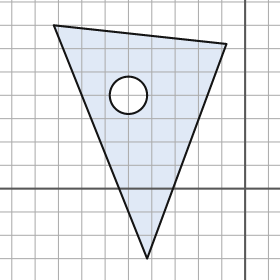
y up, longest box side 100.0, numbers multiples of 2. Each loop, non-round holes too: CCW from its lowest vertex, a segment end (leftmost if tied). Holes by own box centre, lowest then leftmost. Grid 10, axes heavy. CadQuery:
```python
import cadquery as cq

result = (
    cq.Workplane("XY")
    .moveTo(-42.0, -30.0)
    .lineTo(-8.0, 62.0)
    .lineTo(-82.0, 70.0)
    .close()
    .moveTo(-50.0, 40.0)
    .circle(8.0)
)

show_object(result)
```